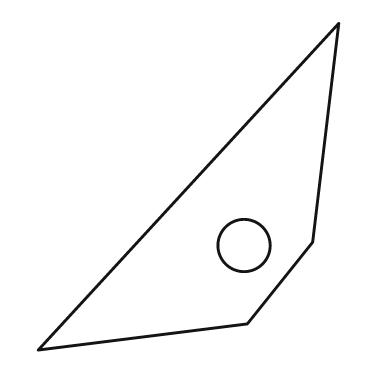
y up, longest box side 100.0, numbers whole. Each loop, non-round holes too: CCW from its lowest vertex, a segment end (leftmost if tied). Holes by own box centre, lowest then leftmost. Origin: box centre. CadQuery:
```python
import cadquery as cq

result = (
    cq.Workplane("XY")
    .moveTo(-46.0, -50.0)
    .lineTo(18.0, -42.0)
    .lineTo(38.0, -17.0)
    .lineTo(46.0, 50.0)
    .close()
    .moveTo(17.0, -18.0)
    .circle(8.0)
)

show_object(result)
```